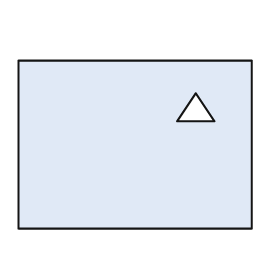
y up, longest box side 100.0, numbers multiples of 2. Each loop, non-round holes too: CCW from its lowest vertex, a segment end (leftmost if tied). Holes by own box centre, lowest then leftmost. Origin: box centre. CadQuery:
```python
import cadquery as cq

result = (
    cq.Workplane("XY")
    .moveTo(-50.0, -36.0)
    .lineTo(50.0, -36.0)
    .lineTo(50.0, 36.0)
    .lineTo(-50.0, 36.0)
    .close()
    .moveTo(18.0, 10.0)
    .lineTo(34.0, 10.0)
    .lineTo(26.0, 22.0)
    .close()
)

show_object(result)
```